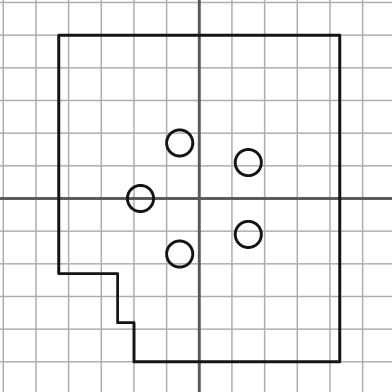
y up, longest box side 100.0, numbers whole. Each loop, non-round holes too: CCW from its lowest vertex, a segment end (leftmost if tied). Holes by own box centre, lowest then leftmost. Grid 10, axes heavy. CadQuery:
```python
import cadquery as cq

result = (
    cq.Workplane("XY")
    .moveTo(-20.0, -50.0)
    .lineTo(43.0, -50.0)
    .lineTo(43.0, 50.0)
    .lineTo(-43.0, 50.0)
    .lineTo(-43.0, -23.0)
    .lineTo(-25.0, -23.0)
    .lineTo(-25.0, -38.0)
    .lineTo(-20.0, -38.0)
    .close()
    .moveTo(-6.0, -17.0)
    .circle(4.0)
    .moveTo(15.0, -11.0)
    .circle(4.0)
    .moveTo(-18.0, 0.0)
    .circle(4.0)
    .moveTo(15.0, 11.0)
    .circle(4.0)
    .moveTo(-6.0, 17.0)
    .circle(4.0)
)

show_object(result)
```